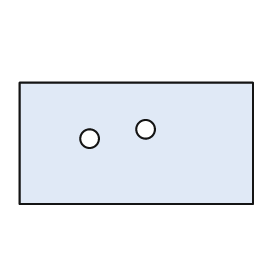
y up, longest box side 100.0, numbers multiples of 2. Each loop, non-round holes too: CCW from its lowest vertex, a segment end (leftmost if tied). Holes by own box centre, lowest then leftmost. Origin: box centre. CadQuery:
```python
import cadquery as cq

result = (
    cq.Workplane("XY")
    .moveTo(-50.0, -26.0)
    .lineTo(50.0, -26.0)
    .lineTo(50.0, 26.0)
    .lineTo(-50.0, 26.0)
    .close()
    .moveTo(-20.0, 2.0)
    .circle(4.0)
    .moveTo(4.0, 6.0)
    .circle(4.0)
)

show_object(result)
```